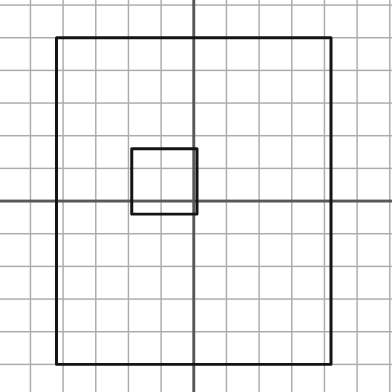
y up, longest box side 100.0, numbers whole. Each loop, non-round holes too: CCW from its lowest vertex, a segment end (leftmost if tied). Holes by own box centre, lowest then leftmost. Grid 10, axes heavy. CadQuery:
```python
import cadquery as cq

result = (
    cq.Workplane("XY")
    .moveTo(-42.0, -50.0)
    .lineTo(42.0, -50.0)
    .lineTo(42.0, 50.0)
    .lineTo(-42.0, 50.0)
    .close()
    .moveTo(-19.0, -4.0)
    .lineTo(1.0, -4.0)
    .lineTo(1.0, 16.0)
    .lineTo(-19.0, 16.0)
    .close()
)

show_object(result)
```